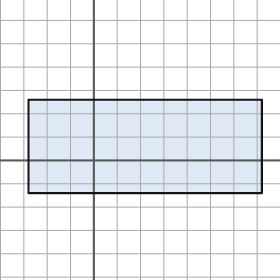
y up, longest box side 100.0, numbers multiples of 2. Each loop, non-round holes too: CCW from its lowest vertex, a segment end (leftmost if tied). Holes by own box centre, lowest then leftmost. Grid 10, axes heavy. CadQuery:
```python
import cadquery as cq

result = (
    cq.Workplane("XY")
    .moveTo(-28.0, -14.0)
    .lineTo(72.0, -14.0)
    .lineTo(72.0, 26.0)
    .lineTo(-28.0, 26.0)
    .close()
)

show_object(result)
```